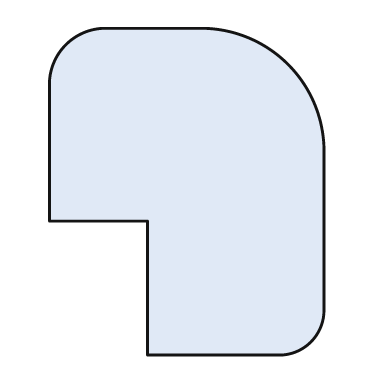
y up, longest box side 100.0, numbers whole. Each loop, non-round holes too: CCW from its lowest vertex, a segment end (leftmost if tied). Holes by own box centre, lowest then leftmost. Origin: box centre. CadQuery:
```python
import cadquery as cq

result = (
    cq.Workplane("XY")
    .moveTo(-12.0, -50.0)
    .lineTo(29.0, -50.0)
    .threePointArc((38.0, -46.0), (42.0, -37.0))
    .lineTo(42.0, 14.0)
    .threePointArc((31.0, 39.0), (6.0, 50.0))
    .lineTo(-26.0, 50.0)
    .threePointArc((-37.0, 45.0), (-42.0, 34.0))
    .lineTo(-42.0, -9.0)
    .lineTo(-12.0, -9.0)
    .close()
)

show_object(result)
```